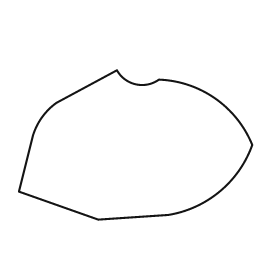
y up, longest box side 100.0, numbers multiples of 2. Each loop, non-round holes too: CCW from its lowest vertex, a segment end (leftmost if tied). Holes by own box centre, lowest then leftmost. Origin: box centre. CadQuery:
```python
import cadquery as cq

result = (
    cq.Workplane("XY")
    .moveTo(-16.0, -32.0)
    .lineTo(14.0, -30.0)
    .threePointArc((36.0, -20.0), (50.0, 0.0))
    .threePointArc((34.0, 20.0), (10.0, 28.0))
    .threePointArc((0.0, 26.0), (-8.0, 32.0))
    .lineTo(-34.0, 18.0)
    .threePointArc((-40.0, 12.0), (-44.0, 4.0))
    .lineTo(-50.0, -20.0)
    .close()
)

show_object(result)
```